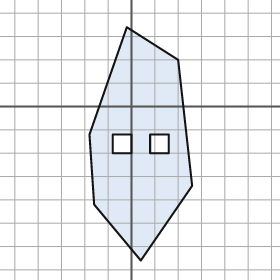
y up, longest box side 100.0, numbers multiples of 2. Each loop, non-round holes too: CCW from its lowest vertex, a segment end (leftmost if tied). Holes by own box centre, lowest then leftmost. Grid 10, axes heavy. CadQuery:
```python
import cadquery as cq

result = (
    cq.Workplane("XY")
    .moveTo(4.0, -66.0)
    .lineTo(26.0, -34.0)
    .lineTo(20.0, 20.0)
    .lineTo(-2.0, 34.0)
    .lineTo(-18.0, -12.0)
    .lineTo(-16.0, -42.0)
    .close()
    .moveTo(-8.0, -20.0)
    .lineTo(0.0, -20.0)
    .lineTo(0.0, -12.0)
    .lineTo(-8.0, -12.0)
    .close()
    .moveTo(8.0, -20.0)
    .lineTo(16.0, -20.0)
    .lineTo(16.0, -12.0)
    .lineTo(8.0, -12.0)
    .close()
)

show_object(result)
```